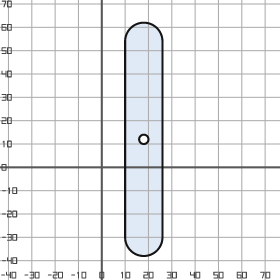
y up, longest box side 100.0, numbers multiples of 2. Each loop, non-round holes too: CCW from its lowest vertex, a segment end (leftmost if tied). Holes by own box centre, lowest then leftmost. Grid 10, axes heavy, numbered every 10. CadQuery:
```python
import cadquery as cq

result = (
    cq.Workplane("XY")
    .moveTo(10.0, -30.0)
    .threePointArc((18.0, -38.0), (26.0, -30.0))
    .lineTo(26.0, 54.0)
    .threePointArc((18.0, 62.0), (10.0, 54.0))
    .close()
    .moveTo(18.0, 12.0)
    .circle(2.0)
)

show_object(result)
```